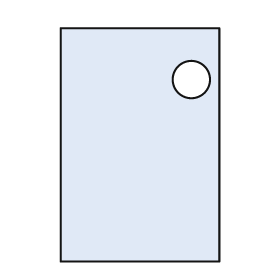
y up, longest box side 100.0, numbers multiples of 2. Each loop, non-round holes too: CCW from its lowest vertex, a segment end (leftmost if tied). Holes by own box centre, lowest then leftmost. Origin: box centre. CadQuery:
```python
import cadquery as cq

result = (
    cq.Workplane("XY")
    .moveTo(-34.0, -50.0)
    .lineTo(34.0, -50.0)
    .lineTo(34.0, 50.0)
    .lineTo(-34.0, 50.0)
    .close()
    .moveTo(22.0, 28.0)
    .circle(8.0)
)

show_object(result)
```